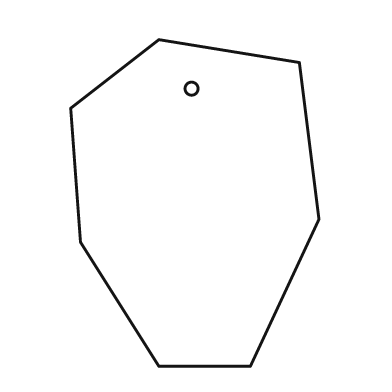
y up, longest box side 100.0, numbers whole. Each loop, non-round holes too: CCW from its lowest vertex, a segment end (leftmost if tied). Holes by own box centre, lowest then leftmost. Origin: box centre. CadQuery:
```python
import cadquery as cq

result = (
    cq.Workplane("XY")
    .moveTo(-11.0, -50.0)
    .lineTo(17.0, -50.0)
    .lineTo(38.0, -5.0)
    .lineTo(32.0, 43.0)
    .lineTo(-11.0, 50.0)
    .lineTo(-38.0, 29.0)
    .lineTo(-35.0, -12.0)
    .close()
    .moveTo(-1.0, 35.0)
    .circle(2.0)
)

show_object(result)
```